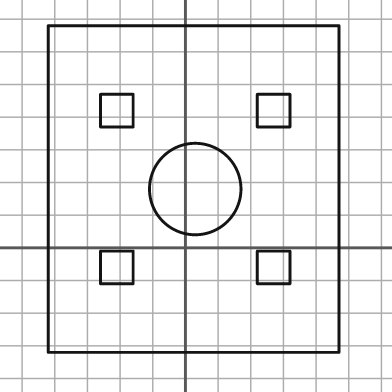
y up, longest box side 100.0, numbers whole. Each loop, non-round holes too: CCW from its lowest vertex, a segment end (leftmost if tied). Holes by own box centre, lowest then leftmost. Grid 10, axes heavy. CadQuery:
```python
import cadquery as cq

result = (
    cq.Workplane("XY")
    .moveTo(-42.0, -32.0)
    .lineTo(47.0, -32.0)
    .lineTo(47.0, 68.0)
    .lineTo(-42.0, 68.0)
    .close()
    .moveTo(-26.0, -11.0)
    .lineTo(-16.0, -11.0)
    .lineTo(-16.0, -1.0)
    .lineTo(-26.0, -1.0)
    .close()
    .moveTo(22.0, -11.0)
    .lineTo(32.0, -11.0)
    .lineTo(32.0, -1.0)
    .lineTo(22.0, -1.0)
    .close()
    .moveTo(3.0, 18.0)
    .circle(14.0)
    .moveTo(-26.0, 37.0)
    .lineTo(-16.0, 37.0)
    .lineTo(-16.0, 47.0)
    .lineTo(-26.0, 47.0)
    .close()
    .moveTo(22.0, 37.0)
    .lineTo(32.0, 37.0)
    .lineTo(32.0, 47.0)
    .lineTo(22.0, 47.0)
    .close()
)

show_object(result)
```